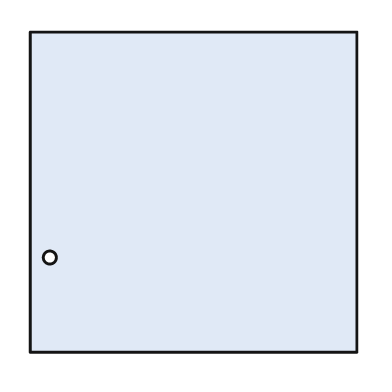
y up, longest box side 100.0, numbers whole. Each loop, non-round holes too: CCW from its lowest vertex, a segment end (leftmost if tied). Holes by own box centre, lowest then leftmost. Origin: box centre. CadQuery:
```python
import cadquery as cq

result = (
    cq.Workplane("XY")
    .moveTo(-50.0, -49.0)
    .lineTo(50.0, -49.0)
    .lineTo(50.0, 49.0)
    .lineTo(-50.0, 49.0)
    .close()
    .moveTo(-44.0, -20.0)
    .circle(2.0)
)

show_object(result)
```